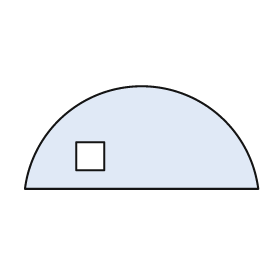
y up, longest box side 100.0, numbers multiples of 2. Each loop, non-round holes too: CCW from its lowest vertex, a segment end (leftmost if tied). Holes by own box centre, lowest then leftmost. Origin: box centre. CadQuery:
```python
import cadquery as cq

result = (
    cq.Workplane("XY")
    .moveTo(-50.0, -22.0)
    .lineTo(50.0, -22.0)
    .threePointArc((0.0, 22.0), (-50.0, -22.0))
    .close()
    .moveTo(-28.0, -14.0)
    .lineTo(-16.0, -14.0)
    .lineTo(-16.0, -2.0)
    .lineTo(-28.0, -2.0)
    .close()
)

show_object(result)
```